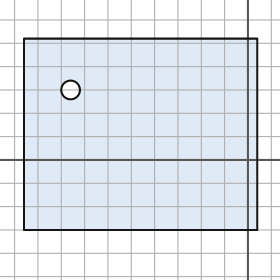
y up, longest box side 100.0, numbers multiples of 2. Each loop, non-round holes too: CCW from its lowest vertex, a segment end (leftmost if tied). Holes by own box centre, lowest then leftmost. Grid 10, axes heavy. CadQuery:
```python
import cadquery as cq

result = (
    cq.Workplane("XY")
    .moveTo(-96.0, -30.0)
    .lineTo(4.0, -30.0)
    .lineTo(4.0, 52.0)
    .lineTo(-96.0, 52.0)
    .close()
    .moveTo(-76.0, 30.0)
    .circle(4.0)
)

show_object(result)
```